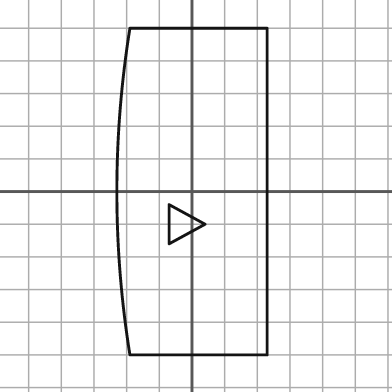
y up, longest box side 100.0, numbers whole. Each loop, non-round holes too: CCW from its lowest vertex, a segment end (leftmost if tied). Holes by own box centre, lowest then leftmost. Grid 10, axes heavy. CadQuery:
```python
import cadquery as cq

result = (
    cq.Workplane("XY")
    .moveTo(-19.0, -50.0)
    .lineTo(23.0, -50.0)
    .lineTo(23.0, 50.0)
    .lineTo(-19.0, 50.0)
    .threePointArc((-23.0, 0.0), (-19.0, -50.0))
    .close()
    .moveTo(-7.0, -16.0)
    .lineTo(4.0, -10.0)
    .lineTo(-7.0, -4.0)
    .close()
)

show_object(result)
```